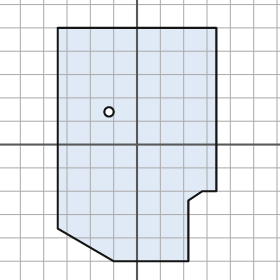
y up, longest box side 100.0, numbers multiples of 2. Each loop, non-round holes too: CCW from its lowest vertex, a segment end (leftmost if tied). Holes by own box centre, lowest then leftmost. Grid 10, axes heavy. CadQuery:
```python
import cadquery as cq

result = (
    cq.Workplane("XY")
    .moveTo(-10.0, -50.0)
    .lineTo(22.0, -50.0)
    .lineTo(22.0, -24.0)
    .lineTo(28.0, -20.0)
    .lineTo(34.0, -20.0)
    .lineTo(34.0, 50.0)
    .lineTo(-34.0, 50.0)
    .lineTo(-34.0, -36.0)
    .close()
    .moveTo(-12.0, 14.0)
    .circle(2.0)
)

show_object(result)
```